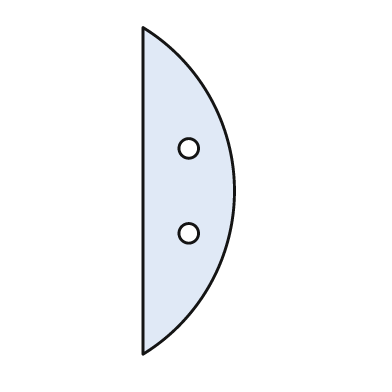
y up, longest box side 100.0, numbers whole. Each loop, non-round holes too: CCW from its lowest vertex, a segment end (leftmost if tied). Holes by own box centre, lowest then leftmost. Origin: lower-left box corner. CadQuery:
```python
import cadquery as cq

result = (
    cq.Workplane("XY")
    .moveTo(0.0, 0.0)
    .threePointArc((28.0, 50.0), (0.0, 100.0))
    .close()
    .moveTo(14.0, 37.0)
    .circle(3.0)
    .moveTo(14.0, 63.0)
    .circle(3.0)
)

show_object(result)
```